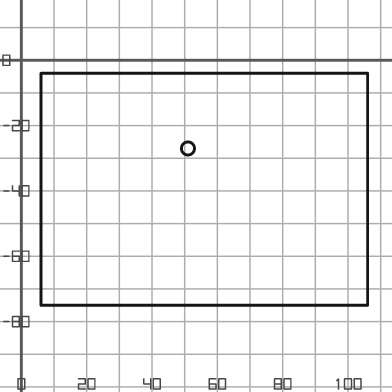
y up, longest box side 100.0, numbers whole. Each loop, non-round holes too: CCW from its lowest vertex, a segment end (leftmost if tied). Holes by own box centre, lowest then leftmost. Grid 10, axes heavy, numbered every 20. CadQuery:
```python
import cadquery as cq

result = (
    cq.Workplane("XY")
    .moveTo(6.0, -75.0)
    .lineTo(106.0, -75.0)
    .lineTo(106.0, -4.0)
    .lineTo(6.0, -4.0)
    .close()
    .moveTo(51.0, -27.0)
    .circle(2.0)
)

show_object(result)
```